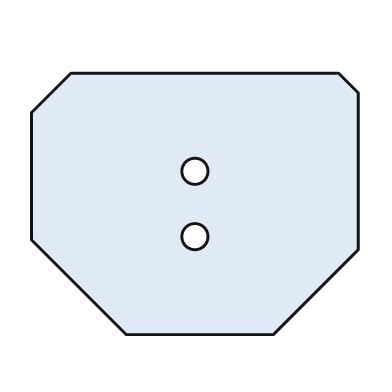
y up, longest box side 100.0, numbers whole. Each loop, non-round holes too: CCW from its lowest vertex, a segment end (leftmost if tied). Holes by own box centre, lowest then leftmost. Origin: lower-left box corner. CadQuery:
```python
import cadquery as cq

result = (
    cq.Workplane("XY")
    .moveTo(29.0, 0.0)
    .lineTo(74.0, 0.0)
    .lineTo(100.0, 26.0)
    .lineTo(100.0, 74.0)
    .lineTo(94.0, 80.0)
    .lineTo(12.0, 80.0)
    .lineTo(0.0, 68.0)
    .lineTo(0.0, 29.0)
    .close()
    .moveTo(50.0, 30.0)
    .circle(4.0)
    .moveTo(50.0, 50.0)
    .circle(4.0)
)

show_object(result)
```